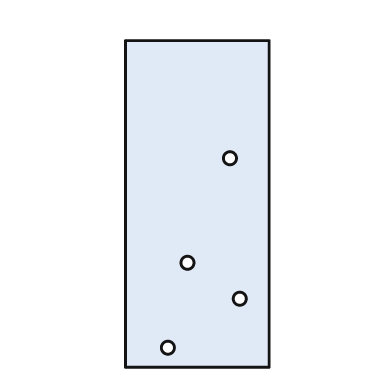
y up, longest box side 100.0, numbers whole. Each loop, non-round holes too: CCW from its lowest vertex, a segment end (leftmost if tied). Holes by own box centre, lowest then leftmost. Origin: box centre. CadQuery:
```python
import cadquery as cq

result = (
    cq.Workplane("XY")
    .moveTo(-22.0, -50.0)
    .lineTo(22.0, -50.0)
    .lineTo(22.0, 50.0)
    .lineTo(-22.0, 50.0)
    .close()
    .moveTo(-9.0, -44.0)
    .circle(2.0)
    .moveTo(13.0, -29.0)
    .circle(2.0)
    .moveTo(-3.0, -18.0)
    .circle(2.0)
    .moveTo(10.0, 14.0)
    .circle(2.0)
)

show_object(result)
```